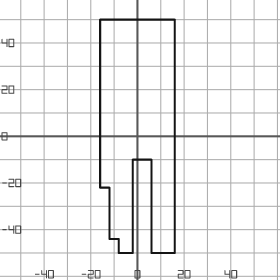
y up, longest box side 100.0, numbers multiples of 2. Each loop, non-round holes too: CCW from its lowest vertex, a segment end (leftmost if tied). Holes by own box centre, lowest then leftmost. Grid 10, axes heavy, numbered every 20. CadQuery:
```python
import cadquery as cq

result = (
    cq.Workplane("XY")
    .moveTo(-8.0, -50.0)
    .lineTo(-2.0, -50.0)
    .lineTo(-2.0, -10.0)
    .lineTo(6.0, -10.0)
    .lineTo(6.0, -50.0)
    .lineTo(16.0, -50.0)
    .lineTo(16.0, 50.0)
    .lineTo(-16.0, 50.0)
    .lineTo(-16.0, -22.0)
    .lineTo(-12.0, -22.0)
    .lineTo(-12.0, -44.0)
    .lineTo(-8.0, -44.0)
    .close()
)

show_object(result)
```